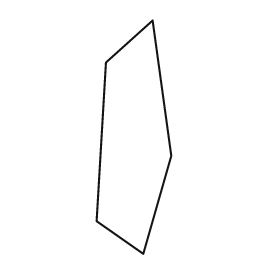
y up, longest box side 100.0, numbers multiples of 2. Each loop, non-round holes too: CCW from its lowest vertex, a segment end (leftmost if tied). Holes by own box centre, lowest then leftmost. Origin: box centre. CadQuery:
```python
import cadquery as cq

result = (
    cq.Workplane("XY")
    .moveTo(4.0, -50.0)
    .lineTo(16.0, -8.0)
    .lineTo(8.0, 50.0)
    .lineTo(-12.0, 32.0)
    .lineTo(-16.0, -36.0)
    .close()
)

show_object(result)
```